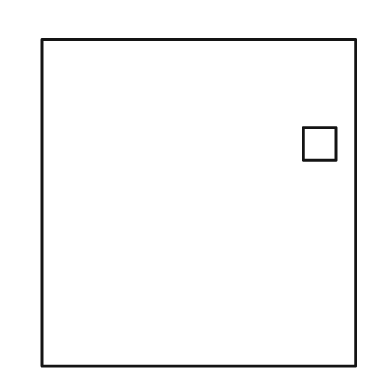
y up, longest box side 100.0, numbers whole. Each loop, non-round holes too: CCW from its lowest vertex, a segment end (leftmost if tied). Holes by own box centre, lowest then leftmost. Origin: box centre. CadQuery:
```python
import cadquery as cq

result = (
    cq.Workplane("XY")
    .moveTo(-48.0, -50.0)
    .lineTo(48.0, -50.0)
    .lineTo(48.0, 50.0)
    .lineTo(-48.0, 50.0)
    .close()
    .moveTo(32.0, 13.0)
    .lineTo(42.0, 13.0)
    .lineTo(42.0, 23.0)
    .lineTo(32.0, 23.0)
    .close()
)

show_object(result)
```